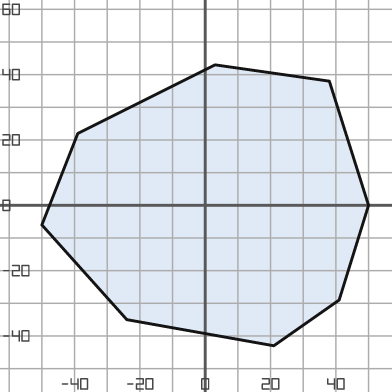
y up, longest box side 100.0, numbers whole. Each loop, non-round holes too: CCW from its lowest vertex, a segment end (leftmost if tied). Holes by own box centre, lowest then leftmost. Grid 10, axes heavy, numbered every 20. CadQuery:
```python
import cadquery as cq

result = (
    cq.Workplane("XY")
    .moveTo(21.0, -43.0)
    .lineTo(41.0, -29.0)
    .lineTo(50.0, 0.0)
    .lineTo(38.0, 38.0)
    .lineTo(3.0, 43.0)
    .lineTo(-39.0, 22.0)
    .lineTo(-50.0, -6.0)
    .lineTo(-24.0, -35.0)
    .close()
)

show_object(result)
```